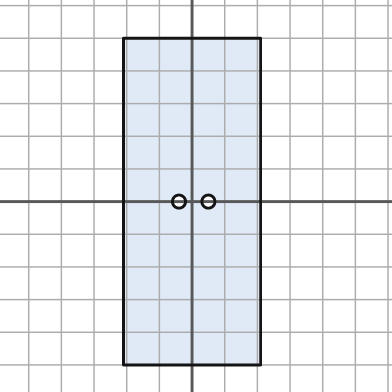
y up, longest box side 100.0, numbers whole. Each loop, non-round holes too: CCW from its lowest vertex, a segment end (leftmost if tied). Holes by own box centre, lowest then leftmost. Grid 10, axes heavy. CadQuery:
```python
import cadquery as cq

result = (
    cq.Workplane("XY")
    .moveTo(-21.0, -50.0)
    .lineTo(21.0, -50.0)
    .lineTo(21.0, 50.0)
    .lineTo(-21.0, 50.0)
    .close()
    .moveTo(-4.0, 0.0)
    .circle(2.0)
    .moveTo(5.0, 0.0)
    .circle(2.0)
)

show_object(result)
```